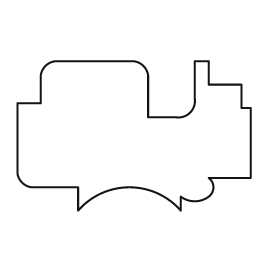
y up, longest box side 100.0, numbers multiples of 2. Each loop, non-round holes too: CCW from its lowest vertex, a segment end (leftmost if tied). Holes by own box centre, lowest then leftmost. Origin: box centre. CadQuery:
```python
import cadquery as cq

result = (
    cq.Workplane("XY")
    .moveTo(-24.0, -32.0)
    .threePointArc((-2.0, -22.0), (20.0, -32.0))
    .lineTo(20.0, -26.0)
    .threePointArc((26.0, -28.0), (32.0, -26.0))
    .threePointArc((34.0, -22.0), (32.0, -18.0))
    .lineTo(50.0, -18.0)
    .lineTo(50.0, 12.0)
    .lineTo(46.0, 12.0)
    .lineTo(46.0, 22.0)
    .lineTo(32.0, 22.0)
    .lineTo(32.0, 32.0)
    .lineTo(26.0, 32.0)
    .lineTo(26.0, 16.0)
    .threePointArc((24.0, 10.0), (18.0, 8.0))
    .lineTo(6.0, 8.0)
    .lineTo(6.0, 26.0)
    .threePointArc((4.0, 30.0), (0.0, 32.0))
    .lineTo(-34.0, 32.0)
    .threePointArc((-38.0, 30.0), (-40.0, 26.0))
    .lineTo(-40.0, 14.0)
    .lineTo(-50.0, 14.0)
    .lineTo(-50.0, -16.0)
    .threePointArc((-48.0, -20.0), (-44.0, -22.0))
    .lineTo(-24.0, -22.0)
    .close()
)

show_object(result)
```